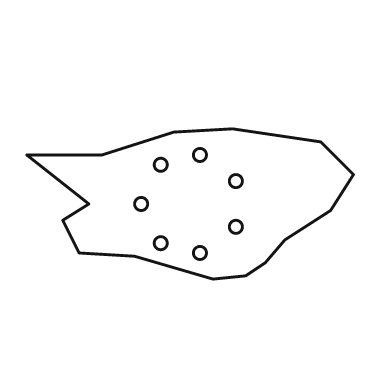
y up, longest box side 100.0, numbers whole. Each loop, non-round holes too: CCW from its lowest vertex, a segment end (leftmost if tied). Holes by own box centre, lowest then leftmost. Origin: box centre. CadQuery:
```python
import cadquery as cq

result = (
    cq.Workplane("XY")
    .moveTo(7.0, -23.0)
    .lineTo(17.0, -22.0)
    .lineTo(23.0, -18.0)
    .lineTo(29.0, -11.0)
    .lineTo(43.0, -2.0)
    .lineTo(50.0, 9.0)
    .lineTo(40.0, 19.0)
    .lineTo(13.0, 23.0)
    .lineTo(-5.0, 22.0)
    .lineTo(-27.0, 15.0)
    .lineTo(-50.0, 15.0)
    .lineTo(-31.0, 0.0)
    .lineTo(-39.0, -5.0)
    .lineTo(-34.0, -15.0)
    .lineTo(-17.0, -16.0)
    .close()
    .moveTo(3.0, -15.0)
    .circle(2.0)
    .moveTo(-9.0, -12.0)
    .circle(2.0)
    .moveTo(14.0, -7.0)
    .circle(2.0)
    .moveTo(-15.0, 0.0)
    .circle(2.0)
    .moveTo(14.0, 7.0)
    .circle(2.0)
    .moveTo(-9.0, 12.0)
    .circle(2.0)
    .moveTo(3.0, 15.0)
    .circle(2.0)
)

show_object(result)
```